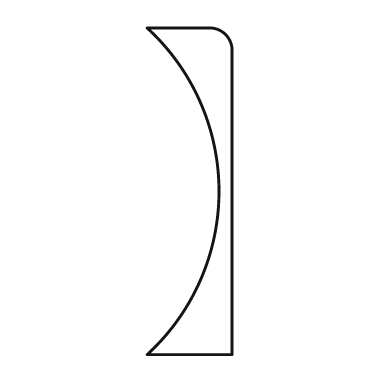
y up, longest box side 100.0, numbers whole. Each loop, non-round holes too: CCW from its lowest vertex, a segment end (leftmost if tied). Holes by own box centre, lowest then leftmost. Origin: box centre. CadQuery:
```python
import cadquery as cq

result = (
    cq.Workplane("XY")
    .moveTo(-13.0, -50.0)
    .lineTo(13.0, -50.0)
    .lineTo(13.0, 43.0)
    .threePointArc((11.0, 48.0), (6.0, 50.0))
    .lineTo(-13.0, 50.0)
    .threePointArc((9.0, 0.0), (-13.0, -50.0))
    .close()
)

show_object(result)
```